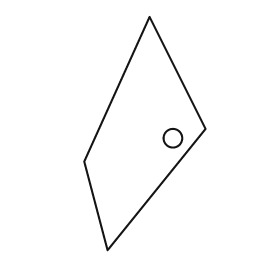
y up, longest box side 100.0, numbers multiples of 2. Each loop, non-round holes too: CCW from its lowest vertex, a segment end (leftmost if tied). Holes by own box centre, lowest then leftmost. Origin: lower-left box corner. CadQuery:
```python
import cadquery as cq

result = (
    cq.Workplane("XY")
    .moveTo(10.0, 0.0)
    .lineTo(52.0, 52.0)
    .lineTo(28.0, 100.0)
    .lineTo(0.0, 38.0)
    .close()
    .moveTo(38.0, 48.0)
    .circle(4.0)
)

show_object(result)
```